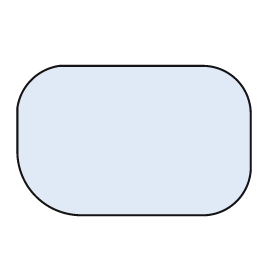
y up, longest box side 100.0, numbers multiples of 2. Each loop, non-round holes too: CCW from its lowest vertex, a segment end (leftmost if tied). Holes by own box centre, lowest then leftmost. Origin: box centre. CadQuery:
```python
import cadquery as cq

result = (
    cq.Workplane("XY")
    .moveTo(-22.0, -32.0)
    .lineTo(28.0, -32.0)
    .threePointArc((44.0, -26.0), (50.0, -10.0))
    .lineTo(50.0, 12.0)
    .threePointArc((44.0, 26.0), (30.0, 32.0))
    .lineTo(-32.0, 32.0)
    .threePointArc((-44.0, 26.0), (-50.0, 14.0))
    .lineTo(-50.0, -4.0)
    .threePointArc((-42.0, -24.0), (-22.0, -32.0))
    .close()
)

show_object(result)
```